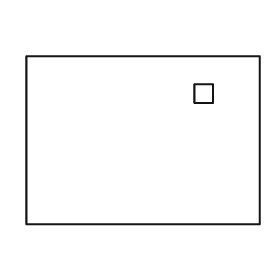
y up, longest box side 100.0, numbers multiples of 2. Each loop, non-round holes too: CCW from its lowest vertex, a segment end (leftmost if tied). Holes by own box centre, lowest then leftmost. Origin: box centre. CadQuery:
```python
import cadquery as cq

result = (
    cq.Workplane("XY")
    .moveTo(-50.0, -36.0)
    .lineTo(50.0, -36.0)
    .lineTo(50.0, 36.0)
    .lineTo(-50.0, 36.0)
    .close()
    .moveTo(22.0, 16.0)
    .lineTo(30.0, 16.0)
    .lineTo(30.0, 24.0)
    .lineTo(22.0, 24.0)
    .close()
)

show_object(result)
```